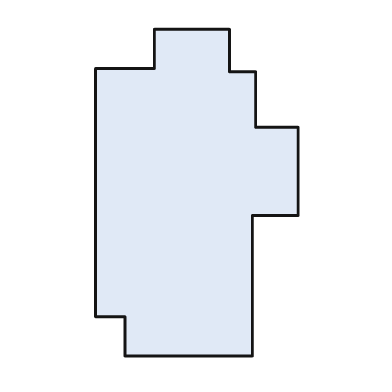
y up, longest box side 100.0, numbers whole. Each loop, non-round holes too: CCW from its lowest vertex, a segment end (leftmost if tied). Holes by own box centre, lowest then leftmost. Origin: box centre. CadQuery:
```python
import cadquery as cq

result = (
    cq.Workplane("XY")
    .moveTo(-22.0, -50.0)
    .lineTo(17.0, -50.0)
    .lineTo(17.0, -7.0)
    .lineTo(31.0, -7.0)
    .lineTo(31.0, 20.0)
    .lineTo(18.0, 20.0)
    .lineTo(18.0, 37.0)
    .lineTo(10.0, 37.0)
    .lineTo(10.0, 50.0)
    .lineTo(-13.0, 50.0)
    .lineTo(-13.0, 38.0)
    .lineTo(-31.0, 38.0)
    .lineTo(-31.0, -38.0)
    .lineTo(-22.0, -38.0)
    .close()
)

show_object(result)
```